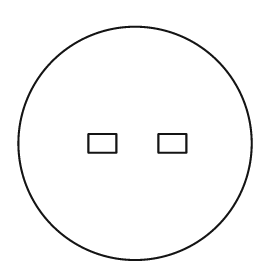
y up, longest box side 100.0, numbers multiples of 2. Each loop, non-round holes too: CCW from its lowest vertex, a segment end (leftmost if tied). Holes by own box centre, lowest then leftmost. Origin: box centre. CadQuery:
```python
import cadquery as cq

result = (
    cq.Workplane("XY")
    .moveTo(0.0, 0.0)
    .circle(50.0)
    .moveTo(-20.0, -4.0)
    .lineTo(-8.0, -4.0)
    .lineTo(-8.0, 4.0)
    .lineTo(-20.0, 4.0)
    .close()
    .moveTo(10.0, -4.0)
    .lineTo(22.0, -4.0)
    .lineTo(22.0, 4.0)
    .lineTo(10.0, 4.0)
    .close()
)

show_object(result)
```